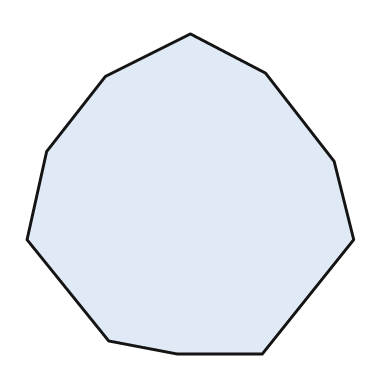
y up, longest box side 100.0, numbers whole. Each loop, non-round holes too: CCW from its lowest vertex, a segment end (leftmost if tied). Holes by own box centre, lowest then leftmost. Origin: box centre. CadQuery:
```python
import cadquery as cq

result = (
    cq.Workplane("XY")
    .moveTo(-4.0, -49.0)
    .lineTo(22.0, -49.0)
    .lineTo(50.0, -14.0)
    .lineTo(44.0, 10.0)
    .lineTo(23.0, 37.0)
    .lineTo(0.0, 49.0)
    .lineTo(-26.0, 36.0)
    .lineTo(-44.0, 13.0)
    .lineTo(-50.0, -14.0)
    .lineTo(-25.0, -45.0)
    .close()
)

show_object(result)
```